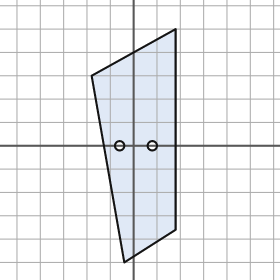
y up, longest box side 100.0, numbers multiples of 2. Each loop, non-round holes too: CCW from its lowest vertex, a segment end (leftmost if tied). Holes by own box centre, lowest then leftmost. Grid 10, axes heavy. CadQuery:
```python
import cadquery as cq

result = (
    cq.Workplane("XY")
    .moveTo(-4.0, -50.0)
    .lineTo(18.0, -36.0)
    .lineTo(18.0, 50.0)
    .lineTo(-18.0, 30.0)
    .close()
    .moveTo(-6.0, 0.0)
    .circle(2.0)
    .moveTo(8.0, 0.0)
    .circle(2.0)
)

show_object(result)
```